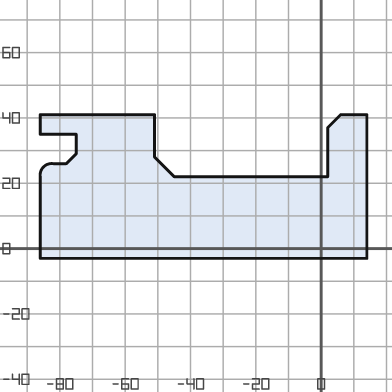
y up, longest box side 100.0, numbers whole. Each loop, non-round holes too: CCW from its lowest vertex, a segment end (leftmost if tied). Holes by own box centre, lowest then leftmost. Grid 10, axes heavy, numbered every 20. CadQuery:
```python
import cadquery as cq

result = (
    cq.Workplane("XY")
    .moveTo(-86.0, -3.0)
    .lineTo(14.0, -3.0)
    .lineTo(14.0, 41.0)
    .lineTo(6.0, 41.0)
    .lineTo(2.0, 37.0)
    .lineTo(2.0, 22.0)
    .lineTo(-45.0, 22.0)
    .lineTo(-51.0, 28.0)
    .lineTo(-51.0, 41.0)
    .lineTo(-86.0, 41.0)
    .lineTo(-86.0, 35.0)
    .lineTo(-75.0, 35.0)
    .lineTo(-75.0, 29.0)
    .lineTo(-78.0, 26.0)
    .lineTo(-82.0, 26.0)
    .threePointArc((-85.0, 25.0), (-86.0, 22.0))
    .close()
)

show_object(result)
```